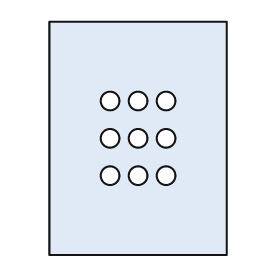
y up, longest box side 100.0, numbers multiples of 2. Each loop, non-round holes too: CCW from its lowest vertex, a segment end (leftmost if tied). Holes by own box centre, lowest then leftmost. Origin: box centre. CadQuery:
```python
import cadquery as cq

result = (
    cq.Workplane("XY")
    .moveTo(-38.0, -50.0)
    .lineTo(38.0, -50.0)
    .lineTo(38.0, 50.0)
    .lineTo(-38.0, 50.0)
    .close()
    .moveTo(-12.0, -16.0)
    .circle(4.0)
    .moveTo(0.0, -16.0)
    .circle(4.0)
    .moveTo(12.0, -16.0)
    .circle(4.0)
    .moveTo(-12.0, 0.0)
    .circle(4.0)
    .moveTo(0.0, 0.0)
    .circle(4.0)
    .moveTo(12.0, 0.0)
    .circle(4.0)
    .moveTo(-12.0, 16.0)
    .circle(4.0)
    .moveTo(0.0, 16.0)
    .circle(4.0)
    .moveTo(12.0, 16.0)
    .circle(4.0)
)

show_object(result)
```